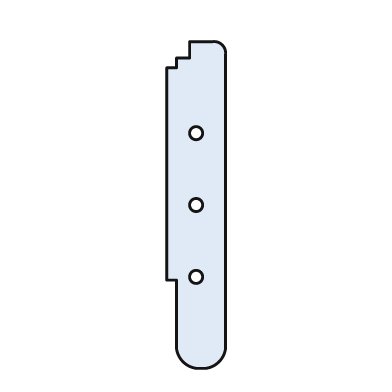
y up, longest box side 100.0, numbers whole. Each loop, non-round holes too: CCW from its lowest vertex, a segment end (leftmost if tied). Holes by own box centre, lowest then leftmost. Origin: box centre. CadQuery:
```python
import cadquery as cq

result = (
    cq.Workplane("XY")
    .moveTo(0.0, -50.0)
    .lineTo(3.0, -50.0)
    .threePointArc((7.0, -48.0), (9.0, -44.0))
    .lineTo(9.0, 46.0)
    .threePointArc((8.0, 49.0), (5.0, 50.0))
    .lineTo(-2.0, 50.0)
    .lineTo(-2.0, 45.0)
    .lineTo(-6.0, 45.0)
    .lineTo(-6.0, 42.0)
    .lineTo(-9.0, 42.0)
    .lineTo(-9.0, -23.0)
    .lineTo(-6.0, -23.0)
    .lineTo(-6.0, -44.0)
    .threePointArc((-4.0, -48.0), (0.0, -50.0))
    .close()
    .moveTo(0.0, -22.0)
    .circle(2.0)
    .moveTo(0.0, 0.0)
    .circle(2.0)
    .moveTo(0.0, 22.0)
    .circle(2.0)
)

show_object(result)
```